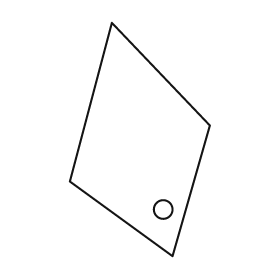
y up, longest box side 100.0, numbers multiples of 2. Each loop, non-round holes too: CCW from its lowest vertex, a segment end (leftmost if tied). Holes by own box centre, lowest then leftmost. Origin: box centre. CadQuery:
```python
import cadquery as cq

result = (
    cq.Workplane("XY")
    .moveTo(14.0, -50.0)
    .lineTo(30.0, 6.0)
    .lineTo(-12.0, 50.0)
    .lineTo(-30.0, -18.0)
    .close()
    .moveTo(10.0, -30.0)
    .circle(4.0)
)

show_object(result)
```